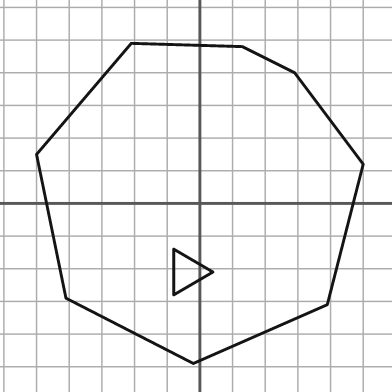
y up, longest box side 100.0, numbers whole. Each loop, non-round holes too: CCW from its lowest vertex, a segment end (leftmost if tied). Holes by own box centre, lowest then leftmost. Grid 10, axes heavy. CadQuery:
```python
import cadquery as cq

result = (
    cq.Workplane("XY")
    .moveTo(-2.0, -49.0)
    .lineTo(39.0, -31.0)
    .lineTo(50.0, 12.0)
    .lineTo(29.0, 40.0)
    .lineTo(13.0, 48.0)
    .lineTo(-21.0, 49.0)
    .lineTo(-50.0, 15.0)
    .lineTo(-41.0, -29.0)
    .close()
    .moveTo(-8.0, -28.0)
    .lineTo(4.0, -21.0)
    .lineTo(-8.0, -14.0)
    .close()
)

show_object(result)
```